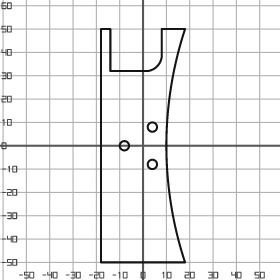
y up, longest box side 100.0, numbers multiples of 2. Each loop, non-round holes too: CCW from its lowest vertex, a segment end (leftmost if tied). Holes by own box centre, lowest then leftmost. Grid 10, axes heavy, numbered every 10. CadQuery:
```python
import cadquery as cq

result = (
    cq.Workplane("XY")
    .moveTo(-18.0, -50.0)
    .lineTo(18.0, -50.0)
    .threePointArc((10.0, 0.0), (18.0, 50.0))
    .lineTo(8.0, 50.0)
    .lineTo(8.0, 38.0)
    .threePointArc((6.0, 34.0), (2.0, 32.0))
    .lineTo(-14.0, 32.0)
    .lineTo(-14.0, 50.0)
    .lineTo(-18.0, 50.0)
    .close()
    .moveTo(4.0, -8.0)
    .circle(2.0)
    .moveTo(-8.0, 0.0)
    .circle(2.0)
    .moveTo(4.0, 8.0)
    .circle(2.0)
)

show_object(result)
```